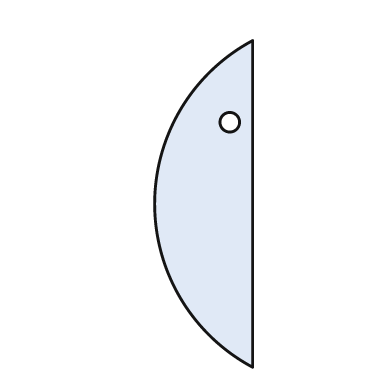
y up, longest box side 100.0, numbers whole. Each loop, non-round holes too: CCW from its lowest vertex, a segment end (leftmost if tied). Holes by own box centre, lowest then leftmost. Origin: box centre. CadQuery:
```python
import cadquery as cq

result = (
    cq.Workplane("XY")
    .moveTo(15.0, -50.0)
    .lineTo(15.0, 50.0)
    .threePointArc((-15.0, 0.0), (15.0, -50.0))
    .close()
    .moveTo(8.0, 25.0)
    .circle(3.0)
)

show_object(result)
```